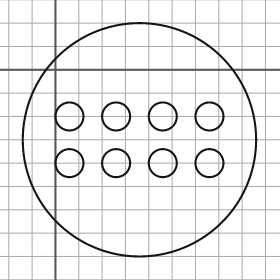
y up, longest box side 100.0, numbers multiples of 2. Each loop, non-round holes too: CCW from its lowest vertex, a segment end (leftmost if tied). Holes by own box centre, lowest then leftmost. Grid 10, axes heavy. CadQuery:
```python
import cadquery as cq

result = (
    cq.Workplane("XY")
    .moveTo(36.0, -30.0)
    .circle(50.0)
    .moveTo(6.0, -40.0)
    .circle(6.0)
    .moveTo(26.0, -40.0)
    .circle(6.0)
    .moveTo(46.0, -40.0)
    .circle(6.0)
    .moveTo(66.0, -40.0)
    .circle(6.0)
    .moveTo(6.0, -20.0)
    .circle(6.0)
    .moveTo(26.0, -20.0)
    .circle(6.0)
    .moveTo(46.0, -20.0)
    .circle(6.0)
    .moveTo(66.0, -20.0)
    .circle(6.0)
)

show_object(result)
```